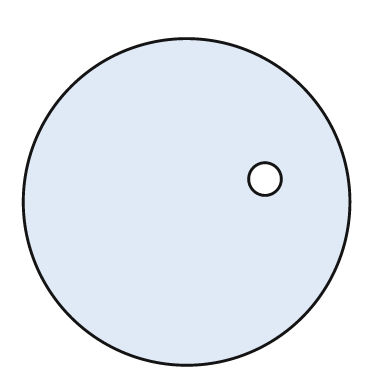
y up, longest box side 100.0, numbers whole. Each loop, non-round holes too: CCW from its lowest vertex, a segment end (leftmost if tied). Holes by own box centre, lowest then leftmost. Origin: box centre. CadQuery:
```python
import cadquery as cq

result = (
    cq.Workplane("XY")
    .moveTo(0.0, 0.0)
    .circle(50.0)
    .moveTo(24.0, 7.0)
    .circle(5.0)
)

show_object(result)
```